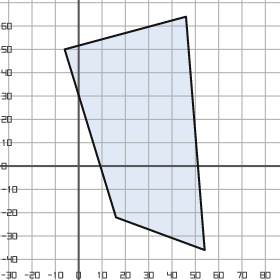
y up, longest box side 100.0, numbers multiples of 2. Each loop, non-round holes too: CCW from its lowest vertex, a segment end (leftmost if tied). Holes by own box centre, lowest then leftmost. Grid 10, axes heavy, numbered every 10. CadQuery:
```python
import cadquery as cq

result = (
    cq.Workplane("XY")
    .moveTo(54.0, -36.0)
    .lineTo(46.0, 64.0)
    .lineTo(-6.0, 50.0)
    .lineTo(16.0, -22.0)
    .close()
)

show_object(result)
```